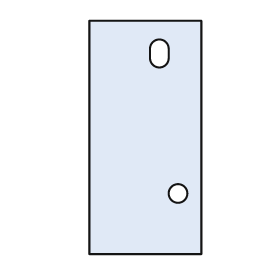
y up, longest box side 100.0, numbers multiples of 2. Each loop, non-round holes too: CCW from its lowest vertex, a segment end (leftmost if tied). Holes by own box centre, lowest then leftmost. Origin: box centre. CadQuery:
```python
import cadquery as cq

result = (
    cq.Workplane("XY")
    .moveTo(-24.0, -50.0)
    .lineTo(24.0, -50.0)
    .lineTo(24.0, 50.0)
    .lineTo(-24.0, 50.0)
    .close()
    .moveTo(14.0, -24.0)
    .circle(4.0)
    .moveTo(2.0, 34.0)
    .threePointArc((6.0, 30.0), (10.0, 34.0))
    .lineTo(10.0, 38.0)
    .threePointArc((6.0, 42.0), (2.0, 38.0))
    .close()
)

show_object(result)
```